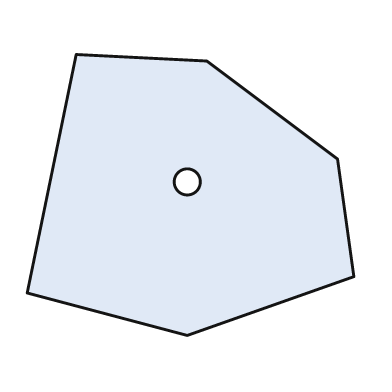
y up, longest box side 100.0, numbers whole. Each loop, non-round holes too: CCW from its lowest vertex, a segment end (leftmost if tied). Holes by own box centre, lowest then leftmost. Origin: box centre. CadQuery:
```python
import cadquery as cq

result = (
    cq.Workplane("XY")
    .moveTo(-1.0, -43.0)
    .lineTo(50.0, -25.0)
    .lineTo(45.0, 11.0)
    .lineTo(5.0, 41.0)
    .lineTo(-35.0, 43.0)
    .lineTo(-50.0, -30.0)
    .close()
    .moveTo(-1.0, 4.0)
    .circle(4.0)
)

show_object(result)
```